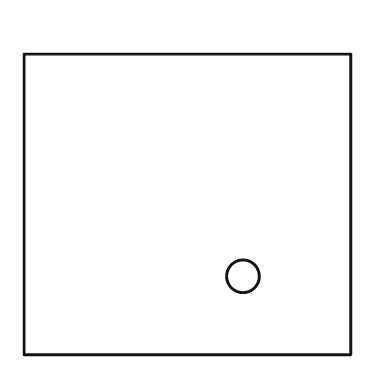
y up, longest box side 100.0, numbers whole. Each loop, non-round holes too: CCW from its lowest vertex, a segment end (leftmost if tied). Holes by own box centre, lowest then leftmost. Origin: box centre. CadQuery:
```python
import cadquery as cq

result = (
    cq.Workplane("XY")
    .moveTo(-50.0, -46.0)
    .lineTo(50.0, -46.0)
    .lineTo(50.0, 46.0)
    .lineTo(-50.0, 46.0)
    .close()
    .moveTo(17.0, -22.0)
    .circle(5.0)
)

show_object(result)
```